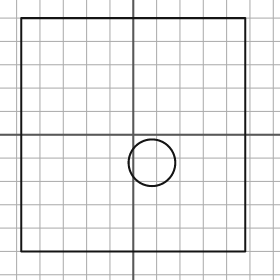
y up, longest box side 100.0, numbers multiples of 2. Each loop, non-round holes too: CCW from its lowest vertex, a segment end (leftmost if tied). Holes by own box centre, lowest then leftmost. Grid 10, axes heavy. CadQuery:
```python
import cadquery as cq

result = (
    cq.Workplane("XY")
    .moveTo(-48.0, -50.0)
    .lineTo(48.0, -50.0)
    .lineTo(48.0, 50.0)
    .lineTo(-48.0, 50.0)
    .close()
    .moveTo(8.0, -12.0)
    .circle(10.0)
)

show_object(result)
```